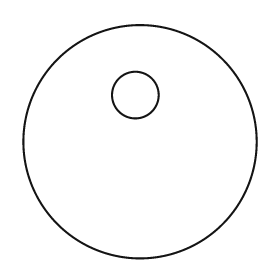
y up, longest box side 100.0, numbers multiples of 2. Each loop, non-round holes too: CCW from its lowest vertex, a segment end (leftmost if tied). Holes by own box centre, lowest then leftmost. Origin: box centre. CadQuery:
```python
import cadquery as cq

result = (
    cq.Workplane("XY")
    .moveTo(0.0, 0.0)
    .circle(50.0)
    .moveTo(-2.0, 20.0)
    .circle(10.0)
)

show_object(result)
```